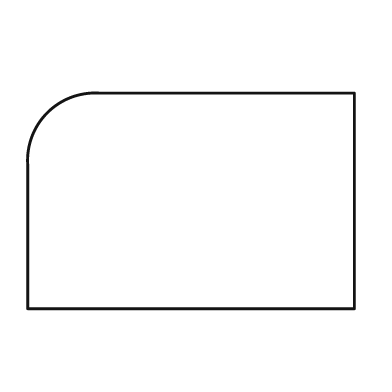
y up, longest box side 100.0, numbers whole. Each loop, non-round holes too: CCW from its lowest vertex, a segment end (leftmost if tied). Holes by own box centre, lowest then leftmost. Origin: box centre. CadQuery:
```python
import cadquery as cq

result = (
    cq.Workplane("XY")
    .moveTo(-50.0, -33.0)
    .lineTo(50.0, -33.0)
    .lineTo(50.0, 33.0)
    .lineTo(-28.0, 33.0)
    .threePointArc((-44.0, 27.0), (-50.0, 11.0))
    .close()
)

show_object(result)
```